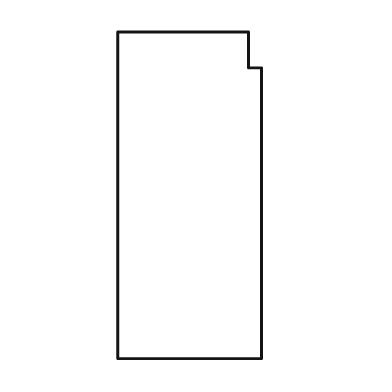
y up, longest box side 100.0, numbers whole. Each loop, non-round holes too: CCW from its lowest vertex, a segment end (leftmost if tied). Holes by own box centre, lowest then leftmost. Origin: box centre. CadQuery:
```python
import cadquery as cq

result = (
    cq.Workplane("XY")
    .moveTo(-22.0, -50.0)
    .lineTo(22.0, -50.0)
    .lineTo(22.0, 39.0)
    .lineTo(18.0, 39.0)
    .lineTo(18.0, 50.0)
    .lineTo(-22.0, 50.0)
    .close()
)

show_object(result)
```